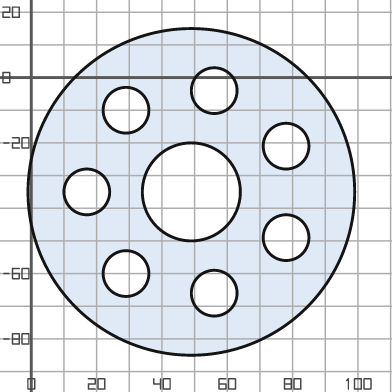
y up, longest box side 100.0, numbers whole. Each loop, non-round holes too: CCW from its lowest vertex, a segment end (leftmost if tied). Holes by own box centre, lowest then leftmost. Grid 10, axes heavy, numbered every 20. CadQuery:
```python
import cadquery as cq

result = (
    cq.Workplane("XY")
    .moveTo(49.0, -35.0)
    .circle(50.0)
    .moveTo(56.0, -66.0)
    .circle(7.0)
    .moveTo(29.0, -60.0)
    .circle(7.0)
    .moveTo(78.0, -49.0)
    .circle(7.0)
    .moveTo(17.0, -35.0)
    .circle(7.0)
    .moveTo(49.0, -35.0)
    .circle(15.0)
    .moveTo(78.0, -21.0)
    .circle(7.0)
    .moveTo(29.0, -10.0)
    .circle(7.0)
    .moveTo(56.0, -4.0)
    .circle(7.0)
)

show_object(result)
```